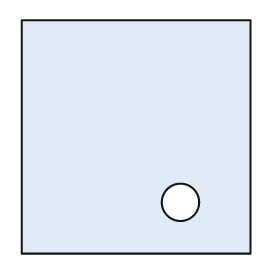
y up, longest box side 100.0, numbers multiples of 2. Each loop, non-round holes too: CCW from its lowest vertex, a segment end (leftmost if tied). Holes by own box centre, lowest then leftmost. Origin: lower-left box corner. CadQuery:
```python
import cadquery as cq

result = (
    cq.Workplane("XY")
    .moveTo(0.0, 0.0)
    .lineTo(98.0, 0.0)
    .lineTo(98.0, 100.0)
    .lineTo(0.0, 100.0)
    .close()
    .moveTo(68.0, 22.0)
    .circle(8.0)
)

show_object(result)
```